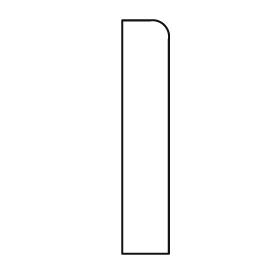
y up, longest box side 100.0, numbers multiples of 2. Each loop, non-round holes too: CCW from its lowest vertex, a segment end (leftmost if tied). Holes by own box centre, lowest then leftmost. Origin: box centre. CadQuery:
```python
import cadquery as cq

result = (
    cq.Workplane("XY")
    .moveTo(-10.0, -50.0)
    .lineTo(10.0, -50.0)
    .lineTo(10.0, 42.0)
    .threePointArc((8.0, 48.0), (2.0, 50.0))
    .lineTo(-10.0, 50.0)
    .close()
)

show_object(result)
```